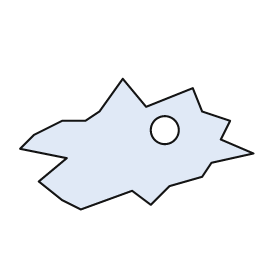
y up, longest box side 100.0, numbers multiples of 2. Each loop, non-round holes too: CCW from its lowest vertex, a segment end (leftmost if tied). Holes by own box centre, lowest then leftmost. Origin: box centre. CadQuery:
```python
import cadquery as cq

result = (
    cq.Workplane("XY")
    .moveTo(-24.0, -28.0)
    .lineTo(-2.0, -20.0)
    .lineTo(6.0, -26.0)
    .lineTo(14.0, -18.0)
    .lineTo(28.0, -14.0)
    .lineTo(32.0, -8.0)
    .lineTo(50.0, -4.0)
    .lineTo(36.0, 2.0)
    .lineTo(40.0, 10.0)
    .lineTo(28.0, 14.0)
    .lineTo(24.0, 24.0)
    .lineTo(4.0, 16.0)
    .lineTo(-6.0, 28.0)
    .lineTo(-16.0, 14.0)
    .lineTo(-22.0, 10.0)
    .lineTo(-32.0, 10.0)
    .lineTo(-44.0, 4.0)
    .lineTo(-50.0, -2.0)
    .lineTo(-30.0, -6.0)
    .lineTo(-42.0, -16.0)
    .lineTo(-32.0, -24.0)
    .close()
    .moveTo(12.0, 6.0)
    .circle(6.0)
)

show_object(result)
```